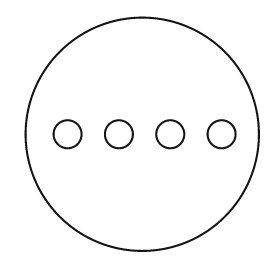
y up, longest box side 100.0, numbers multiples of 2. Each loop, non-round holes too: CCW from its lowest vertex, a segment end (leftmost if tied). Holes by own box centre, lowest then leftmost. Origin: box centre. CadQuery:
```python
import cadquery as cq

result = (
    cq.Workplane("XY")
    .moveTo(0.0, 0.0)
    .circle(50.0)
    .moveTo(-32.0, 0.0)
    .circle(6.0)
    .moveTo(-10.0, 0.0)
    .circle(6.0)
    .moveTo(12.0, 0.0)
    .circle(6.0)
    .moveTo(34.0, 0.0)
    .circle(6.0)
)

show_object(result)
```